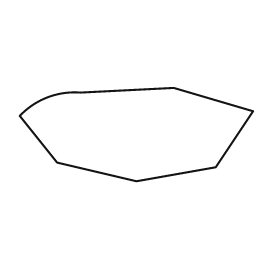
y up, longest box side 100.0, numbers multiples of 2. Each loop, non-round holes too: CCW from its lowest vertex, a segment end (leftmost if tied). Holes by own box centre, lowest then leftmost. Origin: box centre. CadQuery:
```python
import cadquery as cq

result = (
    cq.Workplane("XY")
    .moveTo(0.0, -20.0)
    .lineTo(34.0, -14.0)
    .lineTo(50.0, 10.0)
    .lineTo(16.0, 20.0)
    .lineTo(-24.0, 18.0)
    .threePointArc((-38.0, 16.0), (-50.0, 8.0))
    .lineTo(-34.0, -12.0)
    .close()
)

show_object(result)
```